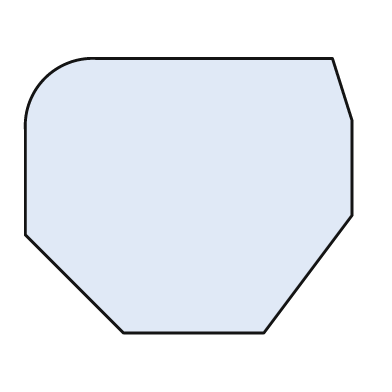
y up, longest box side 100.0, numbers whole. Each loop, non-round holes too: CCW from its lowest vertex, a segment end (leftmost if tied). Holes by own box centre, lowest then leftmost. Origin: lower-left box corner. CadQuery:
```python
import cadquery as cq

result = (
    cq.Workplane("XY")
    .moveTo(30.0, 0.0)
    .lineTo(73.0, 0.0)
    .lineTo(100.0, 36.0)
    .lineTo(100.0, 65.0)
    .lineTo(94.0, 84.0)
    .lineTo(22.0, 84.0)
    .threePointArc((6.0, 78.0), (0.0, 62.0))
    .lineTo(0.0, 30.0)
    .close()
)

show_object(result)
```